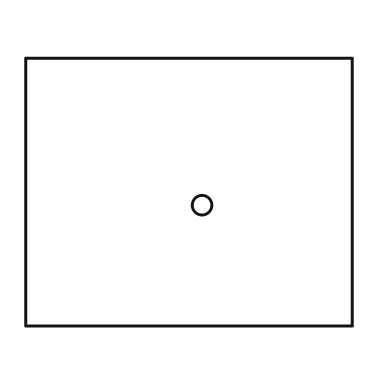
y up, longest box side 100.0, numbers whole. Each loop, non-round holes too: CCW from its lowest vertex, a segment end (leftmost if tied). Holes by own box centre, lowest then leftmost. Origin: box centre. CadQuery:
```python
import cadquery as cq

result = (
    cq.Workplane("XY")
    .moveTo(-50.0, -41.0)
    .lineTo(50.0, -41.0)
    .lineTo(50.0, 41.0)
    .lineTo(-50.0, 41.0)
    .close()
    .moveTo(4.0, -4.0)
    .circle(3.0)
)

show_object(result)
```